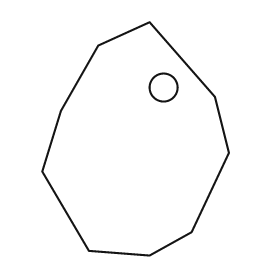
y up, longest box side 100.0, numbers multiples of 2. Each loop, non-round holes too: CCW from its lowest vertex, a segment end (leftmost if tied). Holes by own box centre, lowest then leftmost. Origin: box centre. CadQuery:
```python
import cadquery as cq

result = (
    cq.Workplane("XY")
    .moveTo(6.0, -50.0)
    .lineTo(24.0, -40.0)
    .lineTo(40.0, -6.0)
    .lineTo(34.0, 18.0)
    .lineTo(6.0, 50.0)
    .lineTo(-16.0, 40.0)
    .lineTo(-32.0, 12.0)
    .lineTo(-40.0, -14.0)
    .lineTo(-20.0, -48.0)
    .close()
    .moveTo(12.0, 22.0)
    .circle(6.0)
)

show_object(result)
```